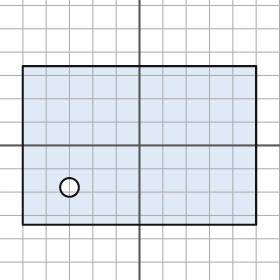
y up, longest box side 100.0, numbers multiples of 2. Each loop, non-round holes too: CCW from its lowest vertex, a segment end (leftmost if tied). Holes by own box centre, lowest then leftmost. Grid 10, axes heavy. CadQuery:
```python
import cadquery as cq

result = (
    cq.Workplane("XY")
    .moveTo(-50.0, -34.0)
    .lineTo(50.0, -34.0)
    .lineTo(50.0, 34.0)
    .lineTo(-50.0, 34.0)
    .close()
    .moveTo(-30.0, -18.0)
    .circle(4.0)
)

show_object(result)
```